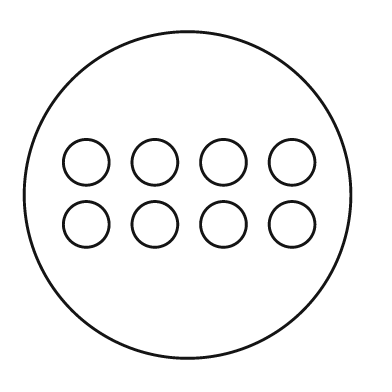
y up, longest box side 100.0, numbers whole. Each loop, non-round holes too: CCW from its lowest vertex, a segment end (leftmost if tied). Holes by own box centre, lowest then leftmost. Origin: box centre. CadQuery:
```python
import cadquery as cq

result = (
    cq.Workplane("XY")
    .moveTo(0.0, 0.0)
    .circle(50.0)
    .moveTo(-31.0, -9.0)
    .circle(7.0)
    .moveTo(-10.0, -9.0)
    .circle(7.0)
    .moveTo(11.0, -9.0)
    .circle(7.0)
    .moveTo(32.0, -9.0)
    .circle(7.0)
    .moveTo(-31.0, 10.0)
    .circle(7.0)
    .moveTo(-10.0, 10.0)
    .circle(7.0)
    .moveTo(11.0, 10.0)
    .circle(7.0)
    .moveTo(32.0, 10.0)
    .circle(7.0)
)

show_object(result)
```